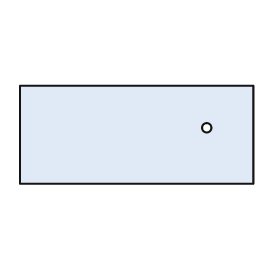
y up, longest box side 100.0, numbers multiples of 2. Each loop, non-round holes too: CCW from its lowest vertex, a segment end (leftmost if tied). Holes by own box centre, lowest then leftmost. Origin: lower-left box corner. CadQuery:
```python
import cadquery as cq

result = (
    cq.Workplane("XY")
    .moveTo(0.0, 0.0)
    .lineTo(100.0, 0.0)
    .lineTo(100.0, 42.0)
    .lineTo(0.0, 42.0)
    .close()
    .moveTo(80.0, 24.0)
    .circle(2.0)
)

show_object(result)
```